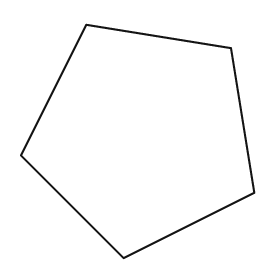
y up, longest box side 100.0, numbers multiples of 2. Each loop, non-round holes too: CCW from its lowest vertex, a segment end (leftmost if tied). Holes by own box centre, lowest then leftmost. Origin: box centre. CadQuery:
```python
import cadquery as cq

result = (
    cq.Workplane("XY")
    .moveTo(-6.0, -50.0)
    .lineTo(50.0, -22.0)
    .lineTo(40.0, 40.0)
    .lineTo(-22.0, 50.0)
    .lineTo(-50.0, -6.0)
    .close()
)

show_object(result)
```